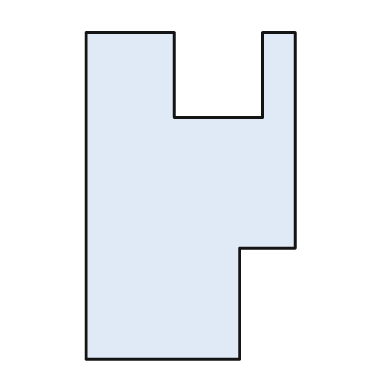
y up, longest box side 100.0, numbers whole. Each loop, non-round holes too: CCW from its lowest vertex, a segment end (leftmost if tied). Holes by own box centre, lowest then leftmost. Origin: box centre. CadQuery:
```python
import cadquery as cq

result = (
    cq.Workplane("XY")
    .moveTo(-32.0, -50.0)
    .lineTo(15.0, -50.0)
    .lineTo(15.0, -16.0)
    .lineTo(32.0, -16.0)
    .lineTo(32.0, 50.0)
    .lineTo(22.0, 50.0)
    .lineTo(22.0, 24.0)
    .lineTo(-5.0, 24.0)
    .lineTo(-5.0, 50.0)
    .lineTo(-32.0, 50.0)
    .close()
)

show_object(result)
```